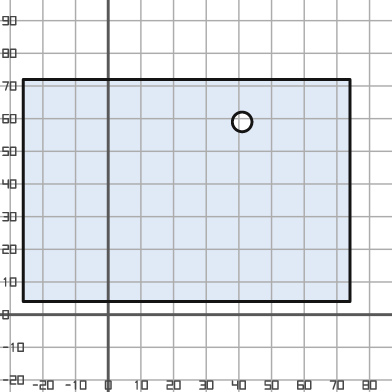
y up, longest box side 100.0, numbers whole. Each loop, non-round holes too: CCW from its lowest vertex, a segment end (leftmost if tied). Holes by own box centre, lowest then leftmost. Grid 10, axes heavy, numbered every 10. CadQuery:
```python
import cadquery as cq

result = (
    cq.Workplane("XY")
    .moveTo(-26.0, 4.0)
    .lineTo(74.0, 4.0)
    .lineTo(74.0, 72.0)
    .lineTo(-26.0, 72.0)
    .close()
    .moveTo(41.0, 59.0)
    .circle(3.0)
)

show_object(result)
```